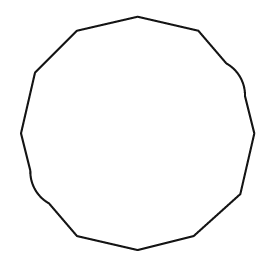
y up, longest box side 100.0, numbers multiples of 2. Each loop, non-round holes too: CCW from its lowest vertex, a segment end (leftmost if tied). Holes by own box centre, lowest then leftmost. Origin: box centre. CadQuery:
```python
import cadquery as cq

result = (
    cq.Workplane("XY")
    .moveTo(0.0, -50.0)
    .lineTo(24.0, -44.0)
    .lineTo(44.0, -26.0)
    .lineTo(50.0, 0.0)
    .lineTo(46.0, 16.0)
    .threePointArc((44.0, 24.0), (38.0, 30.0))
    .lineTo(26.0, 44.0)
    .lineTo(0.0, 50.0)
    .lineTo(-26.0, 44.0)
    .lineTo(-44.0, 26.0)
    .lineTo(-50.0, 0.0)
    .lineTo(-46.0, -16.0)
    .threePointArc((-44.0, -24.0), (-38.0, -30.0))
    .lineTo(-26.0, -44.0)
    .close()
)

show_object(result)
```